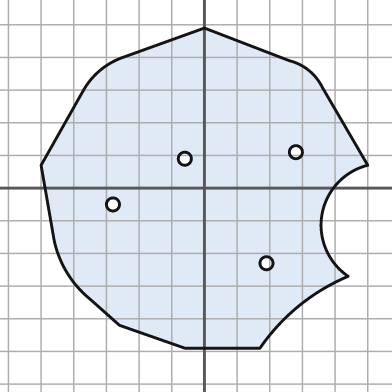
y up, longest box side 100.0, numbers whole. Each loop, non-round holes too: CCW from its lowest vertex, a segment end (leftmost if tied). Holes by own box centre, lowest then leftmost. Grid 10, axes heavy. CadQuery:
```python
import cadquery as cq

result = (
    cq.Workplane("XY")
    .moveTo(-6.0, -49.0)
    .lineTo(17.0, -49.0)
    .threePointArc((29.0, -36.0), (44.0, -27.0))
    .threePointArc((36.0, -8.0), (50.0, 7.0))
    .lineTo(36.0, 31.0)
    .threePointArc((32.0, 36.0), (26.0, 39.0))
    .lineTo(0.0, 49.0)
    .lineTo(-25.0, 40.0)
    .threePointArc((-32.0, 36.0), (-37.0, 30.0))
    .lineTo(-50.0, 7.0)
    .lineTo(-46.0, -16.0)
    .threePointArc((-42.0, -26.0), (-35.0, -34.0))
    .lineTo(-26.0, -42.0)
    .close()
    .moveTo(19.0, -23.0)
    .circle(2.0)
    .moveTo(-28.0, -5.0)
    .circle(2.0)
    .moveTo(-6.0, 9.0)
    .circle(2.0)
    .moveTo(28.0, 11.0)
    .circle(2.0)
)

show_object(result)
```